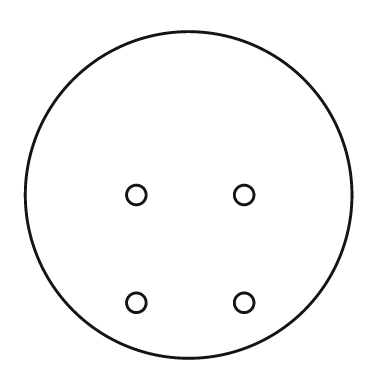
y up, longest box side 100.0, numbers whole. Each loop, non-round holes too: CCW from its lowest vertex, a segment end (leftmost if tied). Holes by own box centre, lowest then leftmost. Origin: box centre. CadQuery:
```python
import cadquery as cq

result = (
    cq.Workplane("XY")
    .moveTo(0.0, 0.0)
    .circle(50.0)
    .moveTo(-16.0, -33.0)
    .circle(3.0)
    .moveTo(17.0, -33.0)
    .circle(3.0)
    .moveTo(-16.0, 0.0)
    .circle(3.0)
    .moveTo(17.0, 0.0)
    .circle(3.0)
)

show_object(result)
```